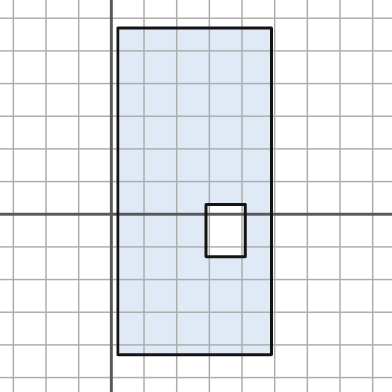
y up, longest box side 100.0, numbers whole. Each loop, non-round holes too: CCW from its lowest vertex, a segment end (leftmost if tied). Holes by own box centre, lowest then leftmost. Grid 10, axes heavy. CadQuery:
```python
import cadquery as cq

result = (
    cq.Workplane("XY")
    .moveTo(2.0, -43.0)
    .lineTo(49.0, -43.0)
    .lineTo(49.0, 57.0)
    .lineTo(2.0, 57.0)
    .close()
    .moveTo(29.0, -13.0)
    .lineTo(41.0, -13.0)
    .lineTo(41.0, 3.0)
    .lineTo(29.0, 3.0)
    .close()
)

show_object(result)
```